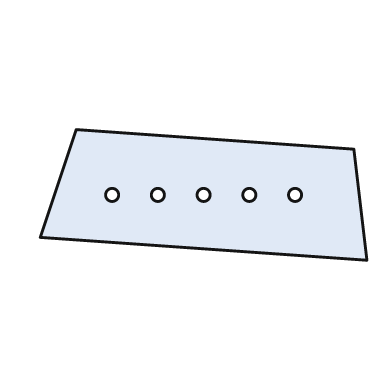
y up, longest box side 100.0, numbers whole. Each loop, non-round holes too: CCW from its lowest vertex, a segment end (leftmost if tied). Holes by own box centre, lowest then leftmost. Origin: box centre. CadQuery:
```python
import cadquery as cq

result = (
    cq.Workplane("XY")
    .moveTo(50.0, -20.0)
    .lineTo(46.0, 14.0)
    .lineTo(-39.0, 20.0)
    .lineTo(-50.0, -13.0)
    .close()
    .moveTo(-28.0, 0.0)
    .circle(2.0)
    .moveTo(-14.0, 0.0)
    .circle(2.0)
    .moveTo(0.0, 0.0)
    .circle(2.0)
    .moveTo(14.0, 0.0)
    .circle(2.0)
    .moveTo(28.0, 0.0)
    .circle(2.0)
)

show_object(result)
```